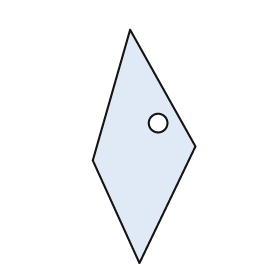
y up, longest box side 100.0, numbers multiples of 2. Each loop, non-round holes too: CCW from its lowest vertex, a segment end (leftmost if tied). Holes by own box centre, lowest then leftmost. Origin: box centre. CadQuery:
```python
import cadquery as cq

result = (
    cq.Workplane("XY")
    .moveTo(-2.0, -50.0)
    .lineTo(22.0, 0.0)
    .lineTo(-6.0, 50.0)
    .lineTo(-22.0, -6.0)
    .close()
    .moveTo(6.0, 10.0)
    .circle(4.0)
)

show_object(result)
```